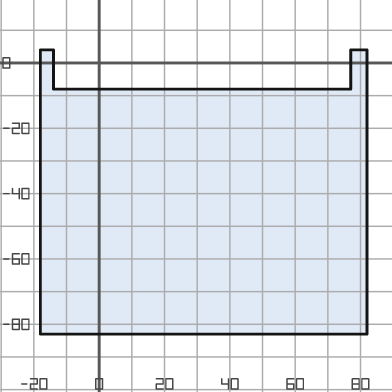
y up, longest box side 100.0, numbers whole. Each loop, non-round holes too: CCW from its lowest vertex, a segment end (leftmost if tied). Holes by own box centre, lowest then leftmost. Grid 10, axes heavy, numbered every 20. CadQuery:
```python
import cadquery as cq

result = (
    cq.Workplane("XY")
    .moveTo(-18.0, -83.0)
    .lineTo(82.0, -83.0)
    .lineTo(82.0, 4.0)
    .lineTo(77.0, 4.0)
    .lineTo(77.0, -8.0)
    .lineTo(-14.0, -8.0)
    .lineTo(-14.0, 4.0)
    .lineTo(-18.0, 4.0)
    .close()
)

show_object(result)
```